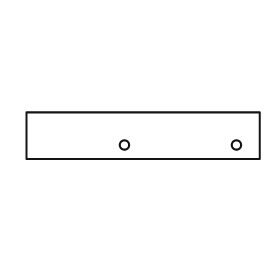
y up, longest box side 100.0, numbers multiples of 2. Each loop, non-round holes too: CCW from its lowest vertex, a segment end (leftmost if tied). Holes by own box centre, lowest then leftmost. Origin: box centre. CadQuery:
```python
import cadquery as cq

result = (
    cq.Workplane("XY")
    .moveTo(-50.0, -10.0)
    .lineTo(50.0, -10.0)
    .lineTo(50.0, 10.0)
    .lineTo(-50.0, 10.0)
    .close()
    .moveTo(-8.0, -4.0)
    .circle(2.0)
    .moveTo(40.0, -4.0)
    .circle(2.0)
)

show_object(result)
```